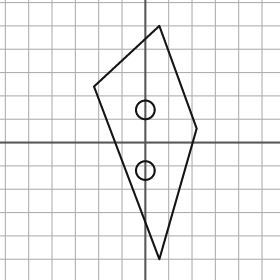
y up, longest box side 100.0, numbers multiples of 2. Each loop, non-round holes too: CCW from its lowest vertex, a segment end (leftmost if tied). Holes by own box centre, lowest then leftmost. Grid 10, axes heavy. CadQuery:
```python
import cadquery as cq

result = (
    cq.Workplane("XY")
    .moveTo(6.0, -50.0)
    .lineTo(22.0, 6.0)
    .lineTo(6.0, 50.0)
    .lineTo(-22.0, 24.0)
    .close()
    .moveTo(0.0, -12.0)
    .circle(4.0)
    .moveTo(0.0, 14.0)
    .circle(4.0)
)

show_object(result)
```